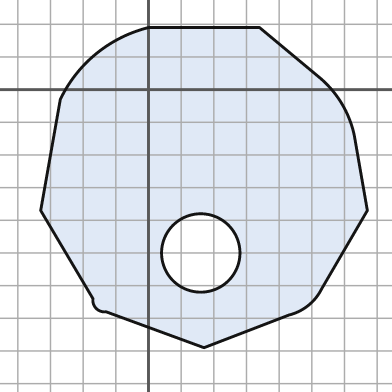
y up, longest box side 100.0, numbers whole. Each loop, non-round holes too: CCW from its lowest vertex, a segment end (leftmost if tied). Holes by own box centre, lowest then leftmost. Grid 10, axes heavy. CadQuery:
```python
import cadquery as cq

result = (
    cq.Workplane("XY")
    .moveTo(17.0, -79.0)
    .lineTo(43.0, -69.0)
    .threePointArc((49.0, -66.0), (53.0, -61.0))
    .lineTo(67.0, -37.0)
    .lineTo(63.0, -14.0)
    .threePointArc((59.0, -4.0), (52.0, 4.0))
    .lineTo(34.0, 19.0)
    .lineTo(0.0, 19.0)
    .threePointArc((-16.0, 11.0), (-27.0, -3.0))
    .lineTo(-33.0, -37.0)
    .lineTo(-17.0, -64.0)
    .threePointArc((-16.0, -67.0), (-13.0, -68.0))
    .close()
    .moveTo(16.0, -50.0)
    .circle(12.0)
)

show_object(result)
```